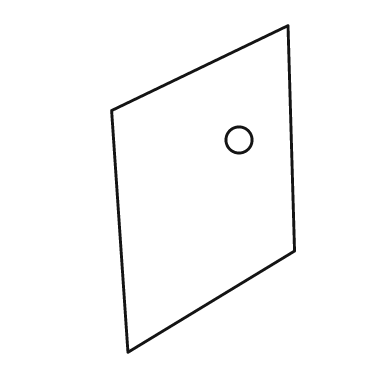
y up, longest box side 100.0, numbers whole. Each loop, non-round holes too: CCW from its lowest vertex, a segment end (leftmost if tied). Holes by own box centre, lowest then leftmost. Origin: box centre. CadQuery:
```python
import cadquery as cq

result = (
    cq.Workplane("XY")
    .moveTo(-23.0, -50.0)
    .lineTo(28.0, -19.0)
    .lineTo(26.0, 50.0)
    .lineTo(-28.0, 24.0)
    .close()
    .moveTo(11.0, 15.0)
    .circle(4.0)
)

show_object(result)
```